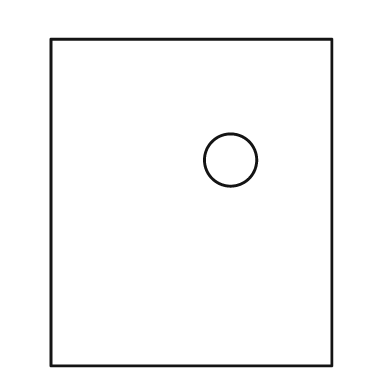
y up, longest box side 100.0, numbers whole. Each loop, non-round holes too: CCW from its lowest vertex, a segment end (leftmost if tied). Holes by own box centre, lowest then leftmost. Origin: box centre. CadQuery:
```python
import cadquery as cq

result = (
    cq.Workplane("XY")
    .moveTo(-43.0, -50.0)
    .lineTo(43.0, -50.0)
    .lineTo(43.0, 50.0)
    .lineTo(-43.0, 50.0)
    .close()
    .moveTo(12.0, 13.0)
    .circle(8.0)
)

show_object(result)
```